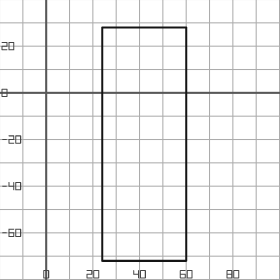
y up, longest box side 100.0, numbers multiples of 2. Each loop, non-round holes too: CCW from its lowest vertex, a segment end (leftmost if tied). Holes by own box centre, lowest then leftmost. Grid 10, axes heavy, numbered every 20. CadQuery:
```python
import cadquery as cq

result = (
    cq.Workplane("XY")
    .moveTo(24.0, -72.0)
    .lineTo(60.0, -72.0)
    .lineTo(60.0, 28.0)
    .lineTo(24.0, 28.0)
    .close()
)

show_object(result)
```